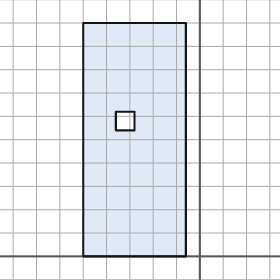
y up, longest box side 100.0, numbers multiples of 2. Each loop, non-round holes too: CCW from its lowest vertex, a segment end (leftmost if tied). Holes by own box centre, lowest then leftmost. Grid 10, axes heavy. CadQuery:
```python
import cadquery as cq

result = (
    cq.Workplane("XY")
    .moveTo(-50.0, 0.0)
    .lineTo(-6.0, 0.0)
    .lineTo(-6.0, 100.0)
    .lineTo(-50.0, 100.0)
    .close()
    .moveTo(-36.0, 54.0)
    .lineTo(-28.0, 54.0)
    .lineTo(-28.0, 62.0)
    .lineTo(-36.0, 62.0)
    .close()
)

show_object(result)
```